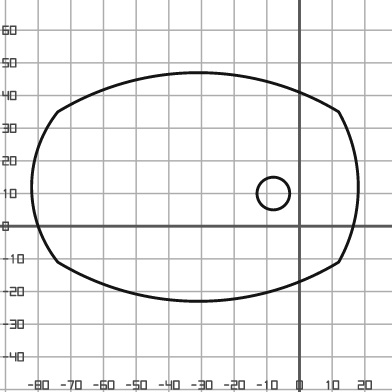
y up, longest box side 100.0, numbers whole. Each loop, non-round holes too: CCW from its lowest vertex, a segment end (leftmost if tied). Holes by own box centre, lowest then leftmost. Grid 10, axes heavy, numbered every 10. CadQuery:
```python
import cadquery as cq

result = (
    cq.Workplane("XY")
    .moveTo(-74.0, -11.0)
    .threePointArc((-31.0, -23.0), (12.0, -11.0))
    .threePointArc((18.0, 12.0), (12.0, 35.0))
    .threePointArc((-31.0, 47.0), (-74.0, 35.0))
    .threePointArc((-82.0, 12.0), (-74.0, -11.0))
    .close()
    .moveTo(-8.0, 10.0)
    .circle(5.0)
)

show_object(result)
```